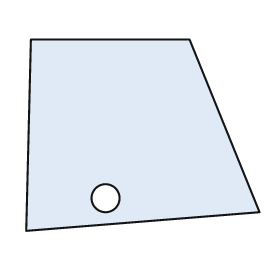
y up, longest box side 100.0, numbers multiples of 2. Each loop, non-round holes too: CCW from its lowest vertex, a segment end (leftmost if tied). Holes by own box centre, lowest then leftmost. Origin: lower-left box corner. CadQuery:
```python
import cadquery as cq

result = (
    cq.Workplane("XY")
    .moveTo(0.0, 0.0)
    .lineTo(100.0, 8.0)
    .lineTo(70.0, 82.0)
    .lineTo(2.0, 82.0)
    .close()
    .moveTo(34.0, 14.0)
    .circle(6.0)
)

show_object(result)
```